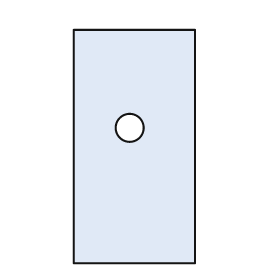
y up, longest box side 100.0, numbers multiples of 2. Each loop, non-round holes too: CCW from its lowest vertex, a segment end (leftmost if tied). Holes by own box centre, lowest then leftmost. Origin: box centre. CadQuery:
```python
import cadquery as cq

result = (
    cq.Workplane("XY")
    .moveTo(-26.0, -50.0)
    .lineTo(26.0, -50.0)
    .lineTo(26.0, 50.0)
    .lineTo(-26.0, 50.0)
    .close()
    .moveTo(-2.0, 8.0)
    .circle(6.0)
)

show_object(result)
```